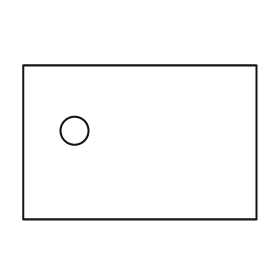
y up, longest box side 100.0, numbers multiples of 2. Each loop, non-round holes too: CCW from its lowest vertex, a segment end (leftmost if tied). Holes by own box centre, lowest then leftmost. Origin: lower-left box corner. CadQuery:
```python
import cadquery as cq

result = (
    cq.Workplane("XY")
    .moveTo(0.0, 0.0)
    .lineTo(100.0, 0.0)
    .lineTo(100.0, 66.0)
    .lineTo(0.0, 66.0)
    .close()
    .moveTo(22.0, 38.0)
    .circle(6.0)
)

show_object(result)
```